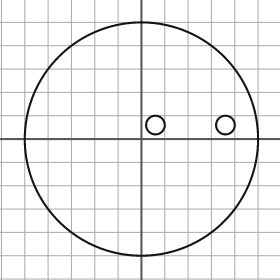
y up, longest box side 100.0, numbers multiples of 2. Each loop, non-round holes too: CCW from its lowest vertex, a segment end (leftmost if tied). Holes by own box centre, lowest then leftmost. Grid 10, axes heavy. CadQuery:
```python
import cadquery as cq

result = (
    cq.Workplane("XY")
    .moveTo(0.0, 0.0)
    .circle(50.0)
    .moveTo(6.0, 6.0)
    .circle(4.0)
    .moveTo(36.0, 6.0)
    .circle(4.0)
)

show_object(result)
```